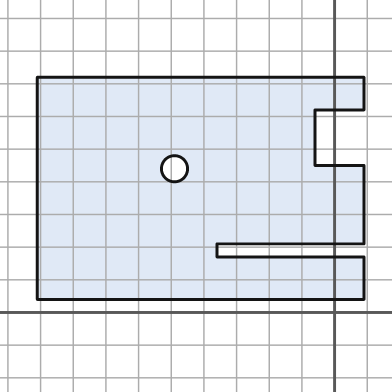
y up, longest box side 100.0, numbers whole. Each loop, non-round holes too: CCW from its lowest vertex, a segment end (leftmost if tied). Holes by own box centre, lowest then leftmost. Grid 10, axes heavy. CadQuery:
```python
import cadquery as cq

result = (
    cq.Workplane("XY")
    .moveTo(-91.0, 4.0)
    .lineTo(9.0, 4.0)
    .lineTo(9.0, 17.0)
    .lineTo(-36.0, 17.0)
    .lineTo(-36.0, 21.0)
    .lineTo(9.0, 21.0)
    .lineTo(9.0, 45.0)
    .lineTo(-6.0, 45.0)
    .lineTo(-6.0, 62.0)
    .lineTo(9.0, 62.0)
    .lineTo(9.0, 72.0)
    .lineTo(-91.0, 72.0)
    .close()
    .moveTo(-49.0, 44.0)
    .circle(4.0)
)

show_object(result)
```